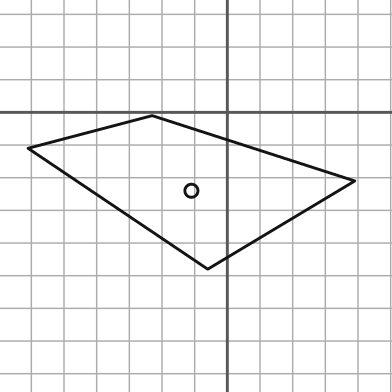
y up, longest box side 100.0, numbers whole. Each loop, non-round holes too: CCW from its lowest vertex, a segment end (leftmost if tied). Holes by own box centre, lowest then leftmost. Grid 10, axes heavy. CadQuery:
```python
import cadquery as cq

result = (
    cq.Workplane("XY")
    .moveTo(-6.0, -48.0)
    .lineTo(39.0, -21.0)
    .lineTo(-23.0, -1.0)
    .lineTo(-61.0, -11.0)
    .close()
    .moveTo(-11.0, -24.0)
    .circle(2.0)
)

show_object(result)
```